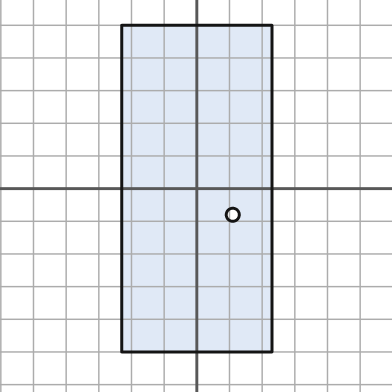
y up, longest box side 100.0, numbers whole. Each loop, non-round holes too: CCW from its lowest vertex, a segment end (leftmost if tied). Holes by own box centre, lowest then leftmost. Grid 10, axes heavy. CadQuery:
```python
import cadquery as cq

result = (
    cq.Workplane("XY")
    .moveTo(-23.0, -50.0)
    .lineTo(23.0, -50.0)
    .lineTo(23.0, 50.0)
    .lineTo(-23.0, 50.0)
    .close()
    .moveTo(11.0, -8.0)
    .circle(2.0)
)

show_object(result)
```